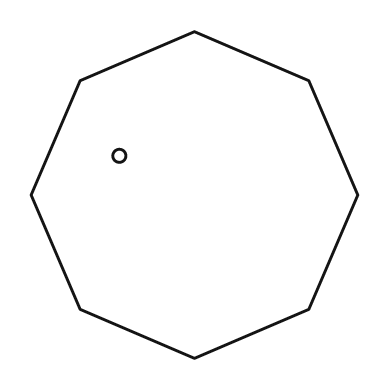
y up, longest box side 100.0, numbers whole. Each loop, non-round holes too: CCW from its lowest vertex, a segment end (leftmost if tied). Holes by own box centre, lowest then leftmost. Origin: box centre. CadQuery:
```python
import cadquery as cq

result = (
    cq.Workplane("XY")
    .moveTo(0.0, -50.0)
    .lineTo(35.0, -35.0)
    .lineTo(50.0, 0.0)
    .lineTo(35.0, 35.0)
    .lineTo(0.0, 50.0)
    .lineTo(-35.0, 35.0)
    .lineTo(-50.0, 0.0)
    .lineTo(-35.0, -35.0)
    .close()
    .moveTo(-23.0, 12.0)
    .circle(2.0)
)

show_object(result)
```